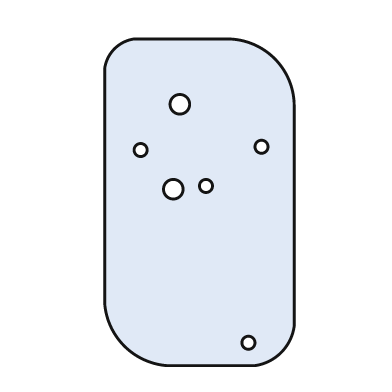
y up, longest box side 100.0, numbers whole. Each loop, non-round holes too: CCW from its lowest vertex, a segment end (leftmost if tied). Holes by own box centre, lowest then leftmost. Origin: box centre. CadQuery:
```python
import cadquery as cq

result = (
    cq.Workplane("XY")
    .moveTo(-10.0, -50.0)
    .lineTo(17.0, -50.0)
    .threePointArc((25.0, -46.0), (29.0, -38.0))
    .lineTo(29.0, 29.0)
    .threePointArc((23.0, 44.0), (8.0, 50.0))
    .lineTo(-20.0, 50.0)
    .threePointArc((-26.0, 47.0), (-29.0, 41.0))
    .lineTo(-29.0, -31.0)
    .threePointArc((-23.0, -44.0), (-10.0, -50.0))
    .close()
    .moveTo(15.0, -43.0)
    .circle(2.0)
    .moveTo(-8.0, 4.0)
    .circle(3.0)
    .moveTo(2.0, 5.0)
    .circle(2.0)
    .moveTo(-18.0, 16.0)
    .circle(2.0)
    .moveTo(19.0, 17.0)
    .circle(2.0)
    .moveTo(-6.0, 30.0)
    .circle(3.0)
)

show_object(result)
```